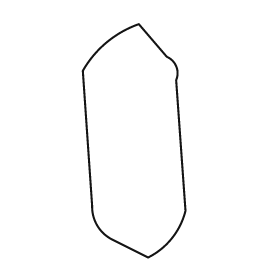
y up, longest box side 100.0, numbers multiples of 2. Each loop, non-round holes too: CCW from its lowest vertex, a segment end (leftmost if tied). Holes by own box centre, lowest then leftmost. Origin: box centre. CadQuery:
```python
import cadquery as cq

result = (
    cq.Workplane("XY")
    .moveTo(6.0, -50.0)
    .threePointArc((16.0, -42.0), (22.0, -30.0))
    .lineTo(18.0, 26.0)
    .threePointArc((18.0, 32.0), (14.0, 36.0))
    .lineTo(2.0, 50.0)
    .threePointArc((-12.0, 42.0), (-22.0, 30.0))
    .lineTo(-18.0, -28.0)
    .threePointArc((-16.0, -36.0), (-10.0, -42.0))
    .close()
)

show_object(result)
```